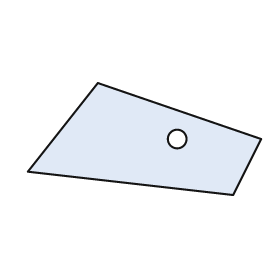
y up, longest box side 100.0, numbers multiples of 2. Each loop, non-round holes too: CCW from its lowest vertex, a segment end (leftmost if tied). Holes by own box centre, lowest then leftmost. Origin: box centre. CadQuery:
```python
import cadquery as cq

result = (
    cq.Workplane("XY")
    .moveTo(38.0, -24.0)
    .lineTo(50.0, 0.0)
    .lineTo(-20.0, 24.0)
    .lineTo(-50.0, -14.0)
    .close()
    .moveTo(14.0, 0.0)
    .circle(4.0)
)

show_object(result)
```